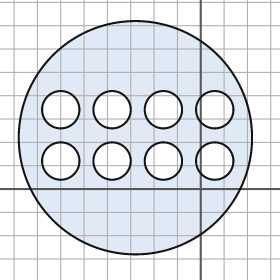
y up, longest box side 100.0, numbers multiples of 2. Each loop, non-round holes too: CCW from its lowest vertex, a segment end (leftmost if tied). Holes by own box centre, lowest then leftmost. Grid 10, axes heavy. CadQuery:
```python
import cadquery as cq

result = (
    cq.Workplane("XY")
    .moveTo(-28.0, 22.0)
    .circle(50.0)
    .moveTo(-60.0, 12.0)
    .circle(8.0)
    .moveTo(-38.0, 12.0)
    .circle(8.0)
    .moveTo(-16.0, 12.0)
    .circle(8.0)
    .moveTo(6.0, 12.0)
    .circle(8.0)
    .moveTo(-60.0, 34.0)
    .circle(8.0)
    .moveTo(-38.0, 34.0)
    .circle(8.0)
    .moveTo(-16.0, 34.0)
    .circle(8.0)
    .moveTo(6.0, 34.0)
    .circle(8.0)
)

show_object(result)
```